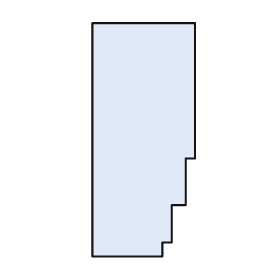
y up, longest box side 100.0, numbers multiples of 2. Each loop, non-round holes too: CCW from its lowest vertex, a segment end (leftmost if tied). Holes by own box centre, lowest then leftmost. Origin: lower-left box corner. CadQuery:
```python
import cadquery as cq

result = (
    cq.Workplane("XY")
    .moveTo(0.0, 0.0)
    .lineTo(30.0, 0.0)
    .lineTo(30.0, 6.0)
    .lineTo(34.0, 6.0)
    .lineTo(34.0, 22.0)
    .lineTo(40.0, 22.0)
    .lineTo(40.0, 42.0)
    .lineTo(44.0, 42.0)
    .lineTo(44.0, 100.0)
    .lineTo(0.0, 100.0)
    .close()
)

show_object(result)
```